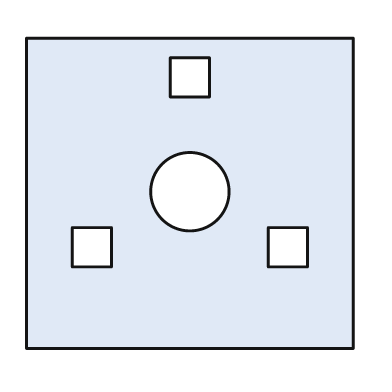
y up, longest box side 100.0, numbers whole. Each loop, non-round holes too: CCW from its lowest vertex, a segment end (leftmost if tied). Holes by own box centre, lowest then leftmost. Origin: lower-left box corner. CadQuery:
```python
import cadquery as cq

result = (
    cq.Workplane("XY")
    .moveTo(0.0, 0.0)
    .lineTo(100.0, 0.0)
    .lineTo(100.0, 95.0)
    .lineTo(0.0, 95.0)
    .close()
    .moveTo(14.0, 25.0)
    .lineTo(26.0, 25.0)
    .lineTo(26.0, 37.0)
    .lineTo(14.0, 37.0)
    .close()
    .moveTo(74.0, 25.0)
    .lineTo(86.0, 25.0)
    .lineTo(86.0, 37.0)
    .lineTo(74.0, 37.0)
    .close()
    .moveTo(50.0, 48.0)
    .circle(12.0)
    .moveTo(44.0, 77.0)
    .lineTo(56.0, 77.0)
    .lineTo(56.0, 89.0)
    .lineTo(44.0, 89.0)
    .close()
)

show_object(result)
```